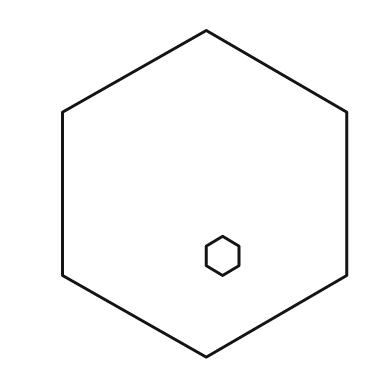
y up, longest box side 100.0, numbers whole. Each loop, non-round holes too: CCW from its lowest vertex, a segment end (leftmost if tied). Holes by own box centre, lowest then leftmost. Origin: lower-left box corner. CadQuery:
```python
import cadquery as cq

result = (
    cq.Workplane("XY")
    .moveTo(44.0, 0.0)
    .lineTo(87.0, 25.0)
    .lineTo(87.0, 75.0)
    .lineTo(44.0, 100.0)
    .lineTo(0.0, 75.0)
    .lineTo(0.0, 25.0)
    .close()
    .moveTo(49.0, 25.0)
    .lineTo(54.0, 28.0)
    .lineTo(54.0, 34.0)
    .lineTo(49.0, 37.0)
    .lineTo(44.0, 34.0)
    .lineTo(44.0, 28.0)
    .close()
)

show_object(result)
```